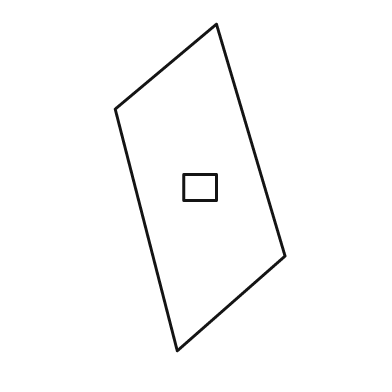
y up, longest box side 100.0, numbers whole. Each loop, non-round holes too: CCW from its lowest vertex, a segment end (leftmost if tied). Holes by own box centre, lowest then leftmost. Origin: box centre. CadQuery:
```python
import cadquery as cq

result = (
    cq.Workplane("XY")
    .moveTo(-7.0, -50.0)
    .lineTo(26.0, -21.0)
    .lineTo(5.0, 50.0)
    .lineTo(-26.0, 24.0)
    .close()
    .moveTo(-5.0, -4.0)
    .lineTo(5.0, -4.0)
    .lineTo(5.0, 4.0)
    .lineTo(-5.0, 4.0)
    .close()
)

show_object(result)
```